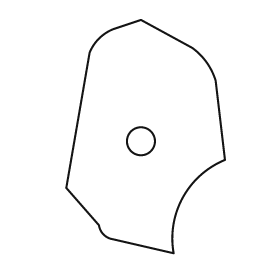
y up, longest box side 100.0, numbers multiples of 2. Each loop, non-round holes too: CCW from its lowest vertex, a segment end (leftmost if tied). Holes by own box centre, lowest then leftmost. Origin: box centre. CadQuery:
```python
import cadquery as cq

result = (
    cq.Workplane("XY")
    .moveTo(12.0, -50.0)
    .threePointArc((16.0, -26.0), (34.0, -10.0))
    .lineTo(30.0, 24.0)
    .threePointArc((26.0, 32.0), (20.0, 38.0))
    .lineTo(-2.0, 50.0)
    .lineTo(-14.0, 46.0)
    .threePointArc((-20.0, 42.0), (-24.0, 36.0))
    .lineTo(-34.0, -22.0)
    .lineTo(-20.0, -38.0)
    .threePointArc((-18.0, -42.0), (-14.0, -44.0))
    .close()
    .moveTo(-2.0, -2.0)
    .circle(6.0)
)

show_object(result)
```